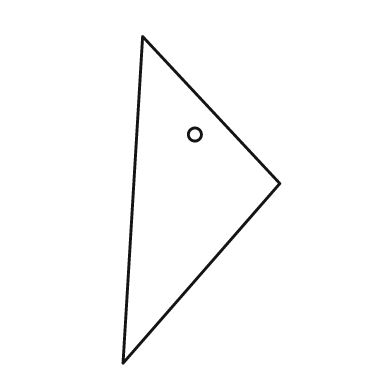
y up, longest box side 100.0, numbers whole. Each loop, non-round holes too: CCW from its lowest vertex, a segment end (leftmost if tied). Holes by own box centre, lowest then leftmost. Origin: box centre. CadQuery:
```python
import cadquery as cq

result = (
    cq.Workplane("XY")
    .moveTo(-24.0, -50.0)
    .lineTo(24.0, 5.0)
    .lineTo(-18.0, 50.0)
    .close()
    .moveTo(-2.0, 20.0)
    .circle(2.0)
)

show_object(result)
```